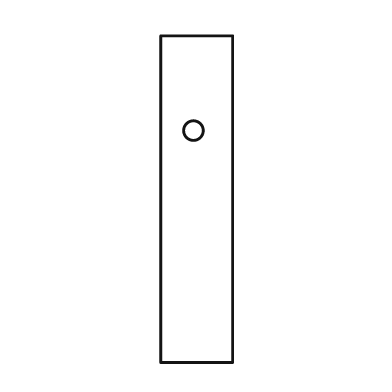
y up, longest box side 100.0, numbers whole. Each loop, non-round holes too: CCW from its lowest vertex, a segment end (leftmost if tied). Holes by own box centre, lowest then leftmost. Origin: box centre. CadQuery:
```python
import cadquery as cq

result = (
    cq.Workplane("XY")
    .moveTo(-11.0, -50.0)
    .lineTo(11.0, -50.0)
    .lineTo(11.0, 50.0)
    .lineTo(-11.0, 50.0)
    .close()
    .moveTo(-1.0, 21.0)
    .circle(3.0)
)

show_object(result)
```